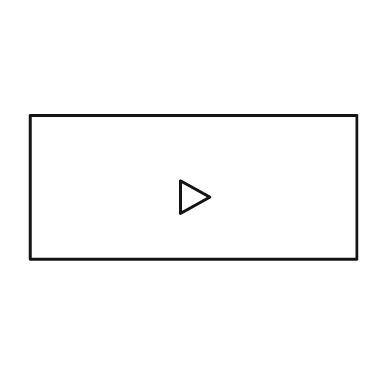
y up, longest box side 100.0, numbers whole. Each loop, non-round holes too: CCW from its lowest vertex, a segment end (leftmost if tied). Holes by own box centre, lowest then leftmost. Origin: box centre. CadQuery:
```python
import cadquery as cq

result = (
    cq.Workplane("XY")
    .moveTo(-50.0, -22.0)
    .lineTo(50.0, -22.0)
    .lineTo(50.0, 22.0)
    .lineTo(-50.0, 22.0)
    .close()
    .moveTo(-4.0, -8.0)
    .lineTo(5.0, -3.0)
    .lineTo(-4.0, 2.0)
    .close()
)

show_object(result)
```